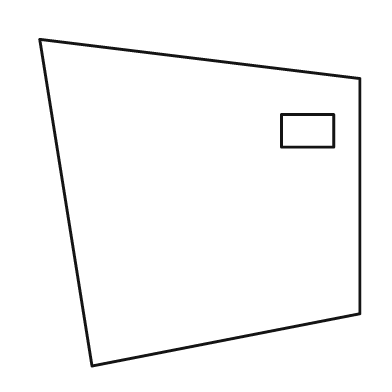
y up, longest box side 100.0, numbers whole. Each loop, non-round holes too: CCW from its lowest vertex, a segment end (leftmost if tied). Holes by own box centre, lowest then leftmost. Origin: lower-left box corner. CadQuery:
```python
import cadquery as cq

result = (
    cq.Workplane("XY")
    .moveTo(16.0, 0.0)
    .lineTo(98.0, 16.0)
    .lineTo(98.0, 88.0)
    .lineTo(0.0, 100.0)
    .close()
    .moveTo(74.0, 67.0)
    .lineTo(90.0, 67.0)
    .lineTo(90.0, 77.0)
    .lineTo(74.0, 77.0)
    .close()
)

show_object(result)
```